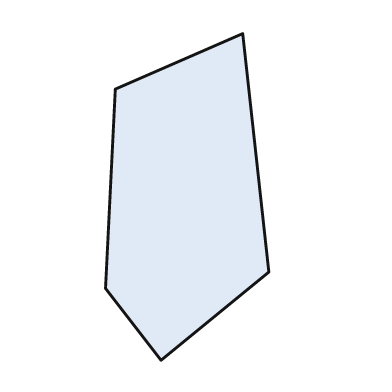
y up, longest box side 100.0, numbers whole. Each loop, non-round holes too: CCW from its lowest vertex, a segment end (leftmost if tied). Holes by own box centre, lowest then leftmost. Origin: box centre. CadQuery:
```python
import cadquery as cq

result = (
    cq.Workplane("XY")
    .moveTo(-8.0, -50.0)
    .lineTo(25.0, -23.0)
    .lineTo(17.0, 50.0)
    .lineTo(-22.0, 33.0)
    .lineTo(-25.0, -28.0)
    .close()
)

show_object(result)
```